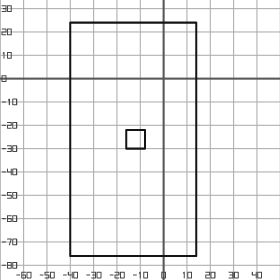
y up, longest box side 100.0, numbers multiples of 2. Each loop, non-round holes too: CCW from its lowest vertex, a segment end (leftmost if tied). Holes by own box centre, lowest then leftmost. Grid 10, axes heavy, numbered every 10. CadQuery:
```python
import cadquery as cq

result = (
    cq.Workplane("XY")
    .moveTo(-40.0, -76.0)
    .lineTo(14.0, -76.0)
    .lineTo(14.0, 24.0)
    .lineTo(-40.0, 24.0)
    .close()
    .moveTo(-16.0, -30.0)
    .lineTo(-8.0, -30.0)
    .lineTo(-8.0, -22.0)
    .lineTo(-16.0, -22.0)
    .close()
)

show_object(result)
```